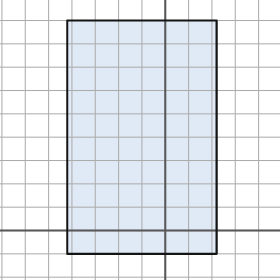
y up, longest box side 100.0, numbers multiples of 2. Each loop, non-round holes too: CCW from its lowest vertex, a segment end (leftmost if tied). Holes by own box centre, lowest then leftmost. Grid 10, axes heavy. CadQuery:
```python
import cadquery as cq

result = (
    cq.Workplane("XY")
    .moveTo(-42.0, -10.0)
    .lineTo(22.0, -10.0)
    .lineTo(22.0, 90.0)
    .lineTo(-42.0, 90.0)
    .close()
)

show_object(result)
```